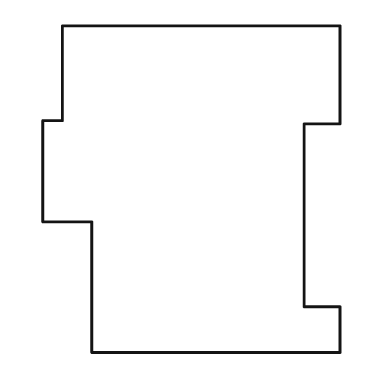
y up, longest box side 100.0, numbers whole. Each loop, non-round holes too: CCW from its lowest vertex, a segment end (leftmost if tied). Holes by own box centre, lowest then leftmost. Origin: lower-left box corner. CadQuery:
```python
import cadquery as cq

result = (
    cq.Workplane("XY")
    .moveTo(15.0, 0.0)
    .lineTo(91.0, 0.0)
    .lineTo(91.0, 14.0)
    .lineTo(80.0, 14.0)
    .lineTo(80.0, 70.0)
    .lineTo(91.0, 70.0)
    .lineTo(91.0, 100.0)
    .lineTo(6.0, 100.0)
    .lineTo(6.0, 71.0)
    .lineTo(0.0, 71.0)
    .lineTo(0.0, 40.0)
    .lineTo(15.0, 40.0)
    .close()
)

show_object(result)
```